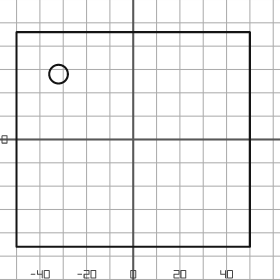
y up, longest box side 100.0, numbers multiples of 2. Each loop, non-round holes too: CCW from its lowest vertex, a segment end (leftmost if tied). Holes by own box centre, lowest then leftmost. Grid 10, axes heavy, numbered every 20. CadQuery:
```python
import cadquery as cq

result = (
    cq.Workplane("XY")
    .moveTo(-50.0, -46.0)
    .lineTo(50.0, -46.0)
    .lineTo(50.0, 46.0)
    .lineTo(-50.0, 46.0)
    .close()
    .moveTo(-32.0, 28.0)
    .circle(4.0)
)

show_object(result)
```